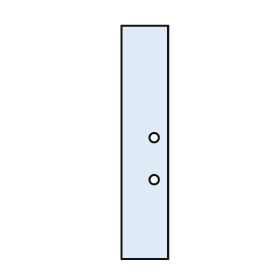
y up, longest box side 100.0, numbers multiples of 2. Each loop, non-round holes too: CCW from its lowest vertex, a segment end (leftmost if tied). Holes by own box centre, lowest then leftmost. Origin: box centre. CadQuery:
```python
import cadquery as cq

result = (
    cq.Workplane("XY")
    .moveTo(-10.0, -50.0)
    .lineTo(10.0, -50.0)
    .lineTo(10.0, 50.0)
    .lineTo(-10.0, 50.0)
    .close()
    .moveTo(4.0, -16.0)
    .circle(2.0)
    .moveTo(4.0, 2.0)
    .circle(2.0)
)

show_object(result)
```